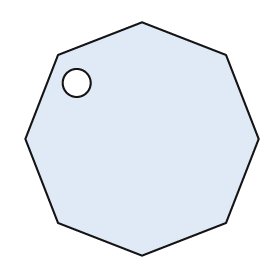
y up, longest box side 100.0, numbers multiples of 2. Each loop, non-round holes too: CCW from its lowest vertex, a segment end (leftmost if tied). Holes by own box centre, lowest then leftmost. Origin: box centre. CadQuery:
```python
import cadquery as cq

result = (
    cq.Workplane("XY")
    .moveTo(0.0, -50.0)
    .lineTo(36.0, -36.0)
    .lineTo(50.0, 0.0)
    .lineTo(36.0, 36.0)
    .lineTo(0.0, 50.0)
    .lineTo(-36.0, 36.0)
    .lineTo(-50.0, 0.0)
    .lineTo(-36.0, -36.0)
    .close()
    .moveTo(-28.0, 24.0)
    .circle(6.0)
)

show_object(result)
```